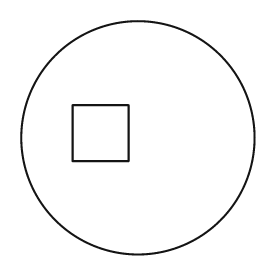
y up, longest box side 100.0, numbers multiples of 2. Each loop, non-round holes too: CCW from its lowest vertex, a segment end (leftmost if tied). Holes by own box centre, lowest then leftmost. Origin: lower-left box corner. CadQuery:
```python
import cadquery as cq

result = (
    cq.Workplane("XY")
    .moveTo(50.0, 50.0)
    .circle(50.0)
    .moveTo(22.0, 40.0)
    .lineTo(46.0, 40.0)
    .lineTo(46.0, 64.0)
    .lineTo(22.0, 64.0)
    .close()
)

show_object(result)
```